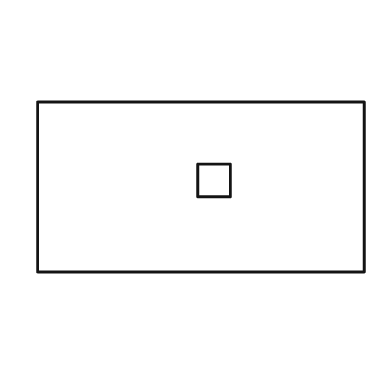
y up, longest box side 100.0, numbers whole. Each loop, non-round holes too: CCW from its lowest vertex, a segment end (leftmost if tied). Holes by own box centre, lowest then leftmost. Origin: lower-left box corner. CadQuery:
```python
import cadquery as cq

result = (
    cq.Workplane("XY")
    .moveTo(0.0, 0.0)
    .lineTo(100.0, 0.0)
    .lineTo(100.0, 52.0)
    .lineTo(0.0, 52.0)
    .close()
    .moveTo(49.0, 23.0)
    .lineTo(59.0, 23.0)
    .lineTo(59.0, 33.0)
    .lineTo(49.0, 33.0)
    .close()
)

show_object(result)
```